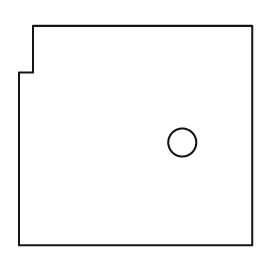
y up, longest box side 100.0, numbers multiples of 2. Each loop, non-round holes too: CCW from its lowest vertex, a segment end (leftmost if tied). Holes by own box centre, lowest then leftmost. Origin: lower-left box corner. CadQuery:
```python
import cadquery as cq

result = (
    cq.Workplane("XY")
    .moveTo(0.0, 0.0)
    .lineTo(100.0, 0.0)
    .lineTo(100.0, 94.0)
    .lineTo(6.0, 94.0)
    .lineTo(6.0, 74.0)
    .lineTo(0.0, 74.0)
    .close()
    .moveTo(70.0, 44.0)
    .circle(6.0)
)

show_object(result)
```